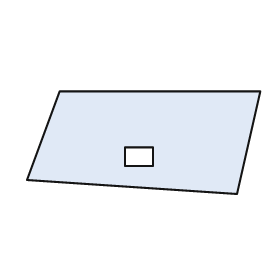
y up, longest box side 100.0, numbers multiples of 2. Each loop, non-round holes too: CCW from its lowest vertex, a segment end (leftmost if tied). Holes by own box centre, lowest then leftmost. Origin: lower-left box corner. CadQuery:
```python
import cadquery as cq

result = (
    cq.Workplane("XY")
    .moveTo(90.0, 0.0)
    .lineTo(100.0, 44.0)
    .lineTo(14.0, 44.0)
    .lineTo(0.0, 6.0)
    .close()
    .moveTo(42.0, 12.0)
    .lineTo(54.0, 12.0)
    .lineTo(54.0, 20.0)
    .lineTo(42.0, 20.0)
    .close()
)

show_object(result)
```